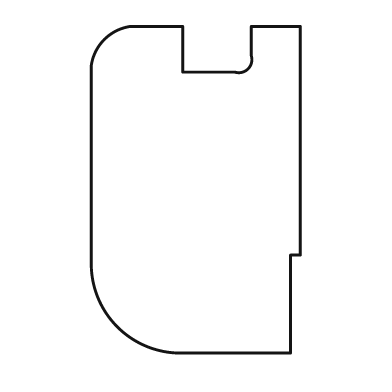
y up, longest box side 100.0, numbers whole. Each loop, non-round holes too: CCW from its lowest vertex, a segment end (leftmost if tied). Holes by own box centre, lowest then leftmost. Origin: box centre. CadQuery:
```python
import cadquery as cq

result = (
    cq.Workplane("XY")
    .moveTo(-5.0, -50.0)
    .lineTo(29.0, -50.0)
    .lineTo(29.0, -20.0)
    .lineTo(32.0, -20.0)
    .lineTo(32.0, 50.0)
    .lineTo(17.0, 50.0)
    .lineTo(17.0, 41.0)
    .threePointArc((16.0, 37.0), (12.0, 36.0))
    .lineTo(-4.0, 36.0)
    .lineTo(-4.0, 50.0)
    .lineTo(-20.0, 50.0)
    .threePointArc((-28.0, 46.0), (-32.0, 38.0))
    .lineTo(-32.0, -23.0)
    .threePointArc((-24.0, -42.0), (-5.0, -50.0))
    .close()
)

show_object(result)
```